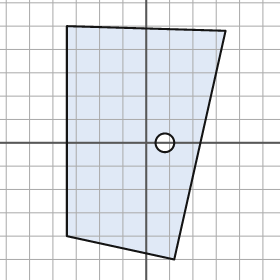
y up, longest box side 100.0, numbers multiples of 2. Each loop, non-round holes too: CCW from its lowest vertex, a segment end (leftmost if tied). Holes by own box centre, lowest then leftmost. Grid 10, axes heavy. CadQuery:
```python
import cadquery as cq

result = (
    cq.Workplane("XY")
    .moveTo(12.0, -50.0)
    .lineTo(34.0, 48.0)
    .lineTo(-34.0, 50.0)
    .lineTo(-34.0, -40.0)
    .close()
    .moveTo(8.0, 0.0)
    .circle(4.0)
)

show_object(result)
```